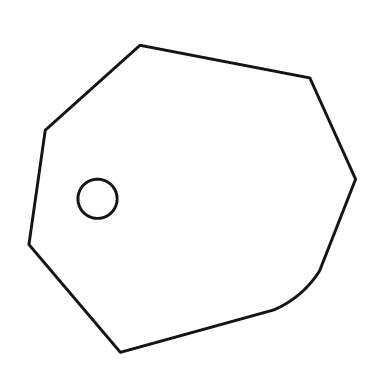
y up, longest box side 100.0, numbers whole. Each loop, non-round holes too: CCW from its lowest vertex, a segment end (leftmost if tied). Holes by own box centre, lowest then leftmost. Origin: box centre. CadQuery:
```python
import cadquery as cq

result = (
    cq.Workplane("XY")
    .moveTo(-22.0, -47.0)
    .lineTo(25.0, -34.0)
    .threePointArc((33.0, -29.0), (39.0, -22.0))
    .lineTo(50.0, 6.0)
    .lineTo(36.0, 37.0)
    .lineTo(-16.0, 47.0)
    .lineTo(-45.0, 21.0)
    .lineTo(-50.0, -14.0)
    .close()
    .moveTo(-29.0, 0.0)
    .circle(6.0)
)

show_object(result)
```